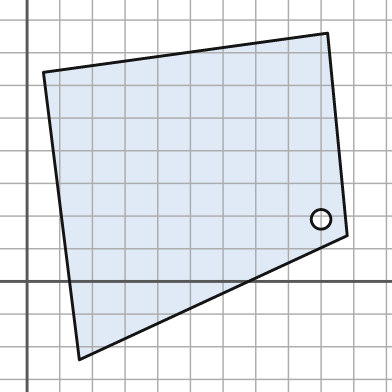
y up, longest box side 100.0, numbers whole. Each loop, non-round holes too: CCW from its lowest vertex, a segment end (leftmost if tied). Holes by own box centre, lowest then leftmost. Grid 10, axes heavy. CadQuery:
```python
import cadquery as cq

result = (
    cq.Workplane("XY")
    .moveTo(16.0, -24.0)
    .lineTo(98.0, 14.0)
    .lineTo(92.0, 76.0)
    .lineTo(5.0, 64.0)
    .close()
    .moveTo(90.0, 19.0)
    .circle(3.0)
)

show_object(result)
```